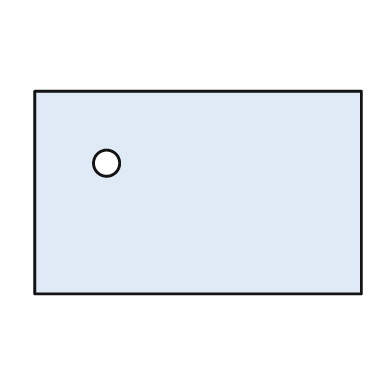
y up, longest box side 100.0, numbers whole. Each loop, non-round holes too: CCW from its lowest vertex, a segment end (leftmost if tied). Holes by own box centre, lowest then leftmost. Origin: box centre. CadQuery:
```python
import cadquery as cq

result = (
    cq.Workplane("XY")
    .moveTo(-50.0, -31.0)
    .lineTo(50.0, -31.0)
    .lineTo(50.0, 31.0)
    .lineTo(-50.0, 31.0)
    .close()
    .moveTo(-28.0, 9.0)
    .circle(4.0)
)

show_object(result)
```